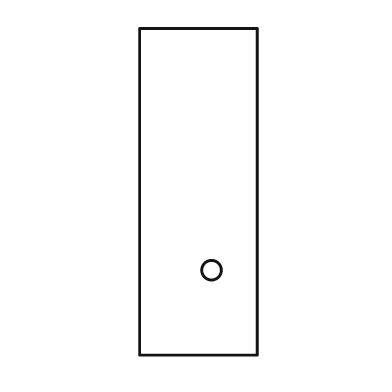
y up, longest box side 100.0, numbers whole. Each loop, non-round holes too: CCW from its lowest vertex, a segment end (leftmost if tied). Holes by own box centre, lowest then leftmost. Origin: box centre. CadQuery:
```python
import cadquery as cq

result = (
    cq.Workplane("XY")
    .moveTo(-18.0, -50.0)
    .lineTo(18.0, -50.0)
    .lineTo(18.0, 50.0)
    .lineTo(-18.0, 50.0)
    .close()
    .moveTo(4.0, -24.0)
    .circle(3.0)
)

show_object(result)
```